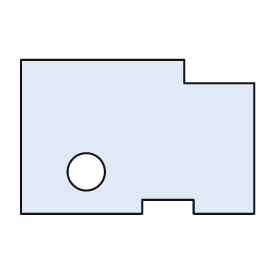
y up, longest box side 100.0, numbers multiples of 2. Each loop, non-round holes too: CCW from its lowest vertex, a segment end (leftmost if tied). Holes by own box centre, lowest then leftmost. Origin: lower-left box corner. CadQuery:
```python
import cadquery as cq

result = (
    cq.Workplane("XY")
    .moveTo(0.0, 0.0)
    .lineTo(52.0, 0.0)
    .lineTo(52.0, 6.0)
    .lineTo(74.0, 6.0)
    .lineTo(74.0, 0.0)
    .lineTo(100.0, 0.0)
    .lineTo(100.0, 56.0)
    .lineTo(70.0, 56.0)
    .lineTo(70.0, 66.0)
    .lineTo(0.0, 66.0)
    .close()
    .moveTo(28.0, 18.0)
    .circle(8.0)
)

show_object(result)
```